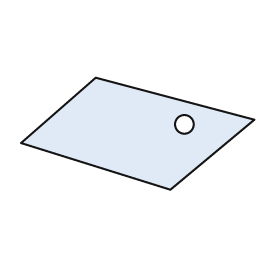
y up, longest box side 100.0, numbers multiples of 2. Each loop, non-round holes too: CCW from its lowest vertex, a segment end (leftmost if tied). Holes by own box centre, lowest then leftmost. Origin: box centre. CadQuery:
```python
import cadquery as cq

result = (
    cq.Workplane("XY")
    .moveTo(14.0, -24.0)
    .lineTo(50.0, 6.0)
    .lineTo(-18.0, 24.0)
    .lineTo(-50.0, -4.0)
    .close()
    .moveTo(20.0, 4.0)
    .circle(4.0)
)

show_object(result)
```